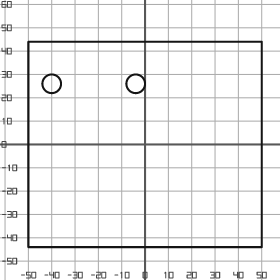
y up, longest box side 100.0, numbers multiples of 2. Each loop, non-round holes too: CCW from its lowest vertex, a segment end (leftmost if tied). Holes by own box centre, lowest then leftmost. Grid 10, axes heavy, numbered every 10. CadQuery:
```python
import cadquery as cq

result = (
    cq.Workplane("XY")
    .moveTo(-50.0, -44.0)
    .lineTo(50.0, -44.0)
    .lineTo(50.0, 44.0)
    .lineTo(-50.0, 44.0)
    .close()
    .moveTo(-40.0, 26.0)
    .circle(4.0)
    .moveTo(-4.0, 26.0)
    .circle(4.0)
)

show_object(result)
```